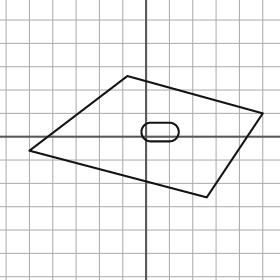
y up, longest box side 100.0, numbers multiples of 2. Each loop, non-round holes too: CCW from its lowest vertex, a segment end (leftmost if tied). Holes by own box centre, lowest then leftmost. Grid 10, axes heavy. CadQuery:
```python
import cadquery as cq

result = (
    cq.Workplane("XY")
    .moveTo(26.0, -26.0)
    .lineTo(50.0, 10.0)
    .lineTo(-8.0, 26.0)
    .lineTo(-50.0, -6.0)
    .close()
    .moveTo(2.0, -2.0)
    .lineTo(10.0, -2.0)
    .threePointArc((14.0, 2.0), (10.0, 6.0))
    .lineTo(2.0, 6.0)
    .threePointArc((-2.0, 2.0), (2.0, -2.0))
    .close()
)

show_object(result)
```